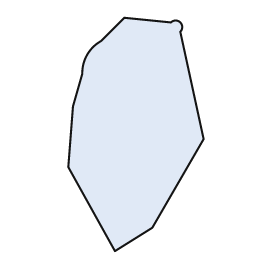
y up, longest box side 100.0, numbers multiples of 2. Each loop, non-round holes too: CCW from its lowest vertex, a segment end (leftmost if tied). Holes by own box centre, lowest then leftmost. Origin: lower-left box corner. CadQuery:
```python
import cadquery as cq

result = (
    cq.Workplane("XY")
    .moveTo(20.0, 0.0)
    .lineTo(36.0, 10.0)
    .lineTo(58.0, 48.0)
    .lineTo(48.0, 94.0)
    .threePointArc((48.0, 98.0), (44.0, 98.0))
    .lineTo(24.0, 100.0)
    .lineTo(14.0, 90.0)
    .threePointArc((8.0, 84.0), (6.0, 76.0))
    .lineTo(2.0, 62.0)
    .lineTo(0.0, 36.0)
    .close()
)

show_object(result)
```